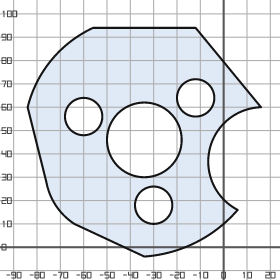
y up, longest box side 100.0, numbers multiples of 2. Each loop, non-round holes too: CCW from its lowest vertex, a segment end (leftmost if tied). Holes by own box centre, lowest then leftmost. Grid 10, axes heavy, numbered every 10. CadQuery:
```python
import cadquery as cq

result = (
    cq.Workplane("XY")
    .moveTo(-34.0, -4.0)
    .threePointArc((-12.0, 2.0), (6.0, 16.0))
    .threePointArc((-6.0, 42.0), (16.0, 60.0))
    .lineTo(-12.0, 94.0)
    .lineTo(-56.0, 94.0)
    .threePointArc((-74.0, 80.0), (-84.0, 60.0))
    .lineTo(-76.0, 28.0)
    .threePointArc((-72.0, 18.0), (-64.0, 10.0))
    .close()
    .moveTo(-30.0, 18.0)
    .circle(8.0)
    .moveTo(-34.0, 46.0)
    .circle(16.0)
    .moveTo(-60.0, 56.0)
    .circle(8.0)
    .moveTo(-12.0, 64.0)
    .circle(8.0)
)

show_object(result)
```